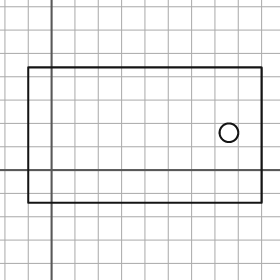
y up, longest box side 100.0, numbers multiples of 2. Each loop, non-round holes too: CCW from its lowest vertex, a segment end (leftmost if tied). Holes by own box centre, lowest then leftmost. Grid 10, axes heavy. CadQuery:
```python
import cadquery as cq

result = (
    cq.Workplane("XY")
    .moveTo(-10.0, -14.0)
    .lineTo(90.0, -14.0)
    .lineTo(90.0, 44.0)
    .lineTo(-10.0, 44.0)
    .close()
    .moveTo(76.0, 16.0)
    .circle(4.0)
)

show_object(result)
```